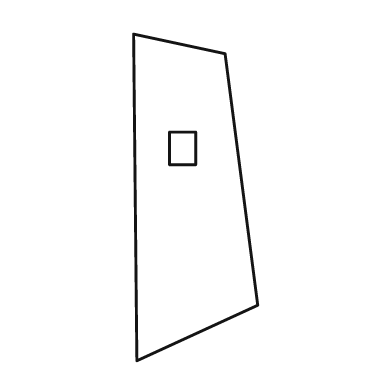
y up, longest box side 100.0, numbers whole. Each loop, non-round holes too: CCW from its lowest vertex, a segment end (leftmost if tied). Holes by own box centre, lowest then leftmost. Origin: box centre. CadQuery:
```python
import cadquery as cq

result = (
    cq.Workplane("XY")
    .moveTo(-18.0, -50.0)
    .lineTo(19.0, -33.0)
    .lineTo(9.0, 44.0)
    .lineTo(-19.0, 50.0)
    .close()
    .moveTo(-8.0, 10.0)
    .lineTo(0.0, 10.0)
    .lineTo(0.0, 20.0)
    .lineTo(-8.0, 20.0)
    .close()
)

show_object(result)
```